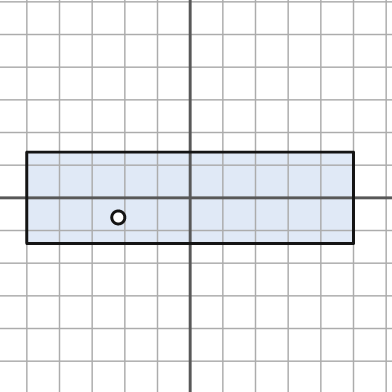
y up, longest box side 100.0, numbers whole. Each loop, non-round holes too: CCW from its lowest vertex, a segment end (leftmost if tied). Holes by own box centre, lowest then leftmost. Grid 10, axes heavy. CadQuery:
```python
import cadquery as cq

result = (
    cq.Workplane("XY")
    .moveTo(-50.0, -14.0)
    .lineTo(50.0, -14.0)
    .lineTo(50.0, 14.0)
    .lineTo(-50.0, 14.0)
    .close()
    .moveTo(-22.0, -6.0)
    .circle(2.0)
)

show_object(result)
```